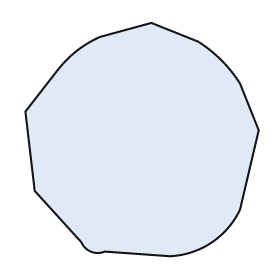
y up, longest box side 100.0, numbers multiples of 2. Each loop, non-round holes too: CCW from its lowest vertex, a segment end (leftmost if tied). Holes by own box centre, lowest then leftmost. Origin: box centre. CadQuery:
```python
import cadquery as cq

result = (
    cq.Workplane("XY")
    .moveTo(12.0, -50.0)
    .threePointArc((30.0, -44.0), (42.0, -30.0))
    .lineTo(50.0, 4.0)
    .lineTo(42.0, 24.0)
    .threePointArc((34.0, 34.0), (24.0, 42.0))
    .lineTo(4.0, 50.0)
    .lineTo(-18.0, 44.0)
    .threePointArc((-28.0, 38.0), (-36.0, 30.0))
    .lineTo(-50.0, 12.0)
    .lineTo(-46.0, -22.0)
    .lineTo(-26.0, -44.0)
    .threePointArc((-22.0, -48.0), (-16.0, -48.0))
    .close()
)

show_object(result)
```